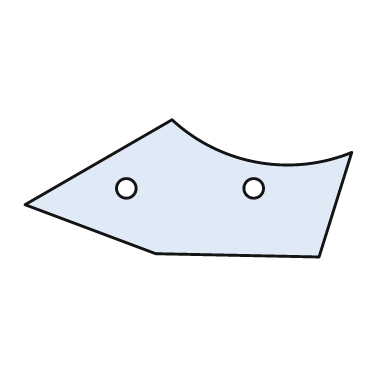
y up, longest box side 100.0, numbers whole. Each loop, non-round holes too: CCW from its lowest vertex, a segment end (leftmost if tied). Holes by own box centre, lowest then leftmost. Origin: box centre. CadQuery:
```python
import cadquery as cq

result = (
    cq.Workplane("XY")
    .moveTo(40.0, -21.0)
    .lineTo(50.0, 11.0)
    .threePointArc((21.0, 8.0), (-5.0, 21.0))
    .lineTo(-50.0, -5.0)
    .lineTo(-10.0, -20.0)
    .close()
    .moveTo(-19.0, 0.0)
    .circle(3.0)
    .moveTo(20.0, 0.0)
    .circle(3.0)
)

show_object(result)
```